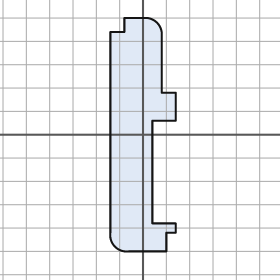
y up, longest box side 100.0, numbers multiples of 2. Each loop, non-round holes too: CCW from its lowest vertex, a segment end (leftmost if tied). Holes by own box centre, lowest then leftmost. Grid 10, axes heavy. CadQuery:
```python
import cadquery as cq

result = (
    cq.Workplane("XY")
    .moveTo(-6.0, -50.0)
    .lineTo(10.0, -50.0)
    .lineTo(10.0, -42.0)
    .lineTo(14.0, -42.0)
    .lineTo(14.0, -38.0)
    .lineTo(4.0, -38.0)
    .lineTo(4.0, 6.0)
    .lineTo(14.0, 6.0)
    .lineTo(14.0, 18.0)
    .lineTo(8.0, 18.0)
    .lineTo(8.0, 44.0)
    .threePointArc((6.0, 48.0), (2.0, 50.0))
    .lineTo(-8.0, 50.0)
    .lineTo(-8.0, 44.0)
    .lineTo(-14.0, 44.0)
    .lineTo(-14.0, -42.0)
    .threePointArc((-12.0, -48.0), (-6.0, -50.0))
    .close()
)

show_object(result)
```